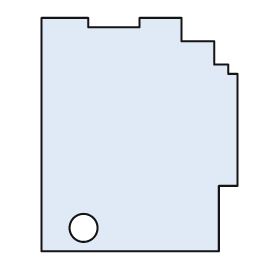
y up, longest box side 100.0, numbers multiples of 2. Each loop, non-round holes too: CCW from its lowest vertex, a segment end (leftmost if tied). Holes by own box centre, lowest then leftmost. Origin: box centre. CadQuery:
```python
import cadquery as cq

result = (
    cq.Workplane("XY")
    .moveTo(-42.0, -50.0)
    .lineTo(34.0, -50.0)
    .lineTo(34.0, -22.0)
    .lineTo(42.0, -22.0)
    .lineTo(42.0, 26.0)
    .lineTo(38.0, 26.0)
    .lineTo(38.0, 30.0)
    .lineTo(32.0, 30.0)
    .lineTo(32.0, 40.0)
    .lineTo(18.0, 40.0)
    .lineTo(18.0, 50.0)
    .lineTo(0.0, 50.0)
    .lineTo(0.0, 46.0)
    .lineTo(-22.0, 46.0)
    .lineTo(-22.0, 50.0)
    .lineTo(-42.0, 50.0)
    .close()
    .moveTo(-24.0, -40.0)
    .circle(6.0)
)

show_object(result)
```